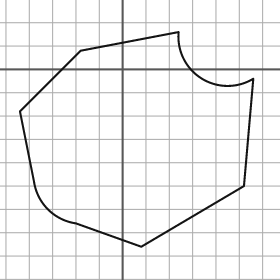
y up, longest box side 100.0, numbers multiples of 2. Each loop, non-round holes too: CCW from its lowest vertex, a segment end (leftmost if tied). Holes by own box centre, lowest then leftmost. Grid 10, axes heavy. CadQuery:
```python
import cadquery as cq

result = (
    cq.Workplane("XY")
    .moveTo(8.0, -76.0)
    .lineTo(52.0, -50.0)
    .lineTo(56.0, -4.0)
    .threePointArc((34.0, -4.0), (24.0, 16.0))
    .lineTo(-18.0, 8.0)
    .lineTo(-44.0, -18.0)
    .lineTo(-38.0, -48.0)
    .threePointArc((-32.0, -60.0), (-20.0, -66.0))
    .close()
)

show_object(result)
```